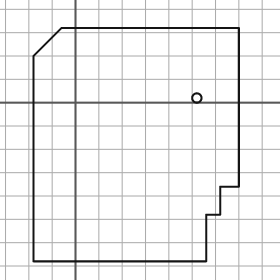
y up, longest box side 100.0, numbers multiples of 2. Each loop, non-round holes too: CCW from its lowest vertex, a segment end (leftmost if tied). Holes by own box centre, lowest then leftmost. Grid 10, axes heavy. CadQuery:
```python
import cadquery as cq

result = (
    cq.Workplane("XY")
    .moveTo(-18.0, -68.0)
    .lineTo(56.0, -68.0)
    .lineTo(56.0, -48.0)
    .lineTo(62.0, -48.0)
    .lineTo(62.0, -36.0)
    .lineTo(70.0, -36.0)
    .lineTo(70.0, 32.0)
    .lineTo(-6.0, 32.0)
    .lineTo(-18.0, 20.0)
    .close()
    .moveTo(52.0, 2.0)
    .circle(2.0)
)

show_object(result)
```